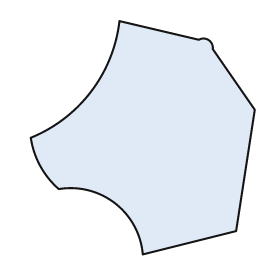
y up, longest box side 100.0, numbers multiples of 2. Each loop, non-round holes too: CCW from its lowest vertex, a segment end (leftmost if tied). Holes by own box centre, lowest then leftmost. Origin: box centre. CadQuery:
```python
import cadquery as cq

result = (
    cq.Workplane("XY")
    .moveTo(0.0, -50.0)
    .lineTo(40.0, -40.0)
    .lineTo(48.0, 12.0)
    .lineTo(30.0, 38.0)
    .threePointArc((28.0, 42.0), (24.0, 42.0))
    .lineTo(-10.0, 50.0)
    .threePointArc((-22.0, 20.0), (-48.0, 0.0))
    .threePointArc((-44.0, -12.0), (-36.0, -22.0))
    .threePointArc((-12.0, -28.0), (0.0, -50.0))
    .close()
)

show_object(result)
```